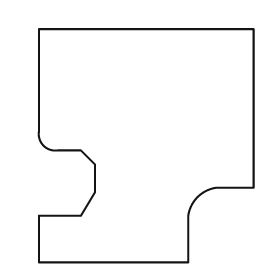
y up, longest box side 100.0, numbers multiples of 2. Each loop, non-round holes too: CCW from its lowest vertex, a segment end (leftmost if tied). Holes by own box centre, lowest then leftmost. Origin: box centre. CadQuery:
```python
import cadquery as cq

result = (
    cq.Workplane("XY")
    .moveTo(-46.0, -50.0)
    .lineTo(18.0, -50.0)
    .lineTo(18.0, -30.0)
    .threePointArc((22.0, -22.0), (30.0, -18.0))
    .lineTo(46.0, -18.0)
    .lineTo(46.0, 50.0)
    .lineTo(-46.0, 50.0)
    .lineTo(-46.0, 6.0)
    .threePointArc((-44.0, 0.0), (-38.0, -2.0))
    .lineTo(-28.0, -2.0)
    .lineTo(-22.0, -8.0)
    .lineTo(-22.0, -20.0)
    .lineTo(-28.0, -30.0)
    .lineTo(-46.0, -30.0)
    .close()
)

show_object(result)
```